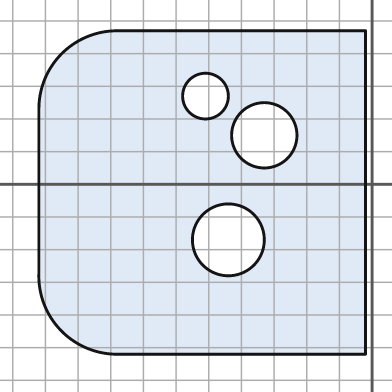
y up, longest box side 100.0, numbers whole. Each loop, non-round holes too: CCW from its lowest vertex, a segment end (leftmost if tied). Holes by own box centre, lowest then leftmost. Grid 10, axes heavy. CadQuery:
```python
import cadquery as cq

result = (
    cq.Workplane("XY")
    .moveTo(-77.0, -52.0)
    .lineTo(-2.0, -52.0)
    .lineTo(-2.0, 47.0)
    .lineTo(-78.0, 47.0)
    .threePointArc((-95.0, 40.0), (-102.0, 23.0))
    .lineTo(-102.0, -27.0)
    .threePointArc((-95.0, -45.0), (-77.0, -52.0))
    .close()
    .moveTo(-44.0, -17.0)
    .circle(11.0)
    .moveTo(-33.0, 15.0)
    .circle(10.0)
    .moveTo(-51.0, 27.0)
    .circle(7.0)
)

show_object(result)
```